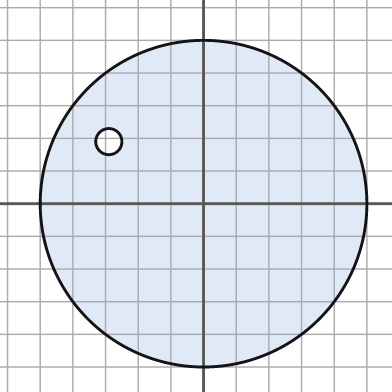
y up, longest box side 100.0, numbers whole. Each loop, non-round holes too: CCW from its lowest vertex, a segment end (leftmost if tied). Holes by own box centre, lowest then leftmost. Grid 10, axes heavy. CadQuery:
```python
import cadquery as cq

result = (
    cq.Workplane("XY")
    .moveTo(0.0, 0.0)
    .circle(50.0)
    .moveTo(-29.0, 19.0)
    .circle(4.0)
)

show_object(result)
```